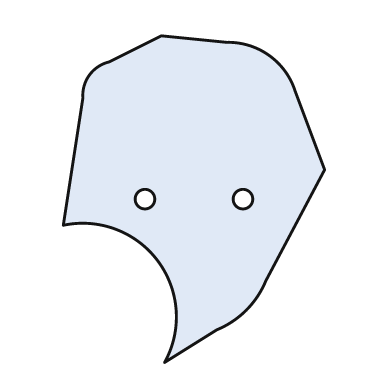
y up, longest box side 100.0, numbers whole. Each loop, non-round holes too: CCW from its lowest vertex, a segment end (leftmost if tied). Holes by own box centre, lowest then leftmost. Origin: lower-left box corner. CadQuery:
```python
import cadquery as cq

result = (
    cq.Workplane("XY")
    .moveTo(31.0, 0.0)
    .lineTo(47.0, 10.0)
    .threePointArc((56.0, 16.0), (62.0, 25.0))
    .lineTo(80.0, 59.0)
    .lineTo(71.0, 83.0)
    .threePointArc((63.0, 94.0), (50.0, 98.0))
    .lineTo(30.0, 100.0)
    .lineTo(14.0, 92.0)
    .threePointArc((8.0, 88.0), (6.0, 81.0))
    .lineTo(0.0, 42.0)
    .threePointArc((29.0, 31.0), (31.0, 0.0))
    .close()
    .moveTo(25.0, 50.0)
    .circle(3.0)
    .moveTo(55.0, 50.0)
    .circle(3.0)
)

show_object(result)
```